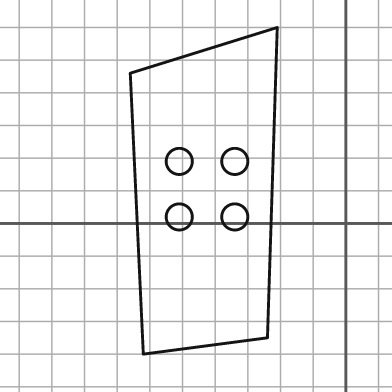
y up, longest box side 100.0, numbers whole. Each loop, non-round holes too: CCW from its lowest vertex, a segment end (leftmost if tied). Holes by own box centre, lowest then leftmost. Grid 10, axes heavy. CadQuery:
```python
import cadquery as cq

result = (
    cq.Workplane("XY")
    .moveTo(-62.0, -40.0)
    .lineTo(-24.0, -35.0)
    .lineTo(-21.0, 60.0)
    .lineTo(-66.0, 46.0)
    .close()
    .moveTo(-51.0, 2.0)
    .circle(4.0)
    .moveTo(-34.0, 2.0)
    .circle(4.0)
    .moveTo(-51.0, 19.0)
    .circle(4.0)
    .moveTo(-34.0, 19.0)
    .circle(4.0)
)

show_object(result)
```